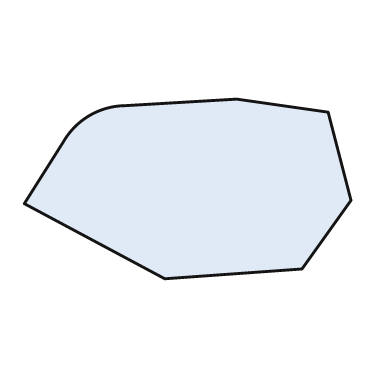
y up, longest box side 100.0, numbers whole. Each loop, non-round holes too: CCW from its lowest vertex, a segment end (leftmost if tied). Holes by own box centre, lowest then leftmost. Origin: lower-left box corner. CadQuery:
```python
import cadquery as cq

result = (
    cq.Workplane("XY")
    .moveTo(43.0, 0.0)
    .lineTo(85.0, 3.0)
    .lineTo(100.0, 24.0)
    .lineTo(93.0, 51.0)
    .lineTo(65.0, 55.0)
    .lineTo(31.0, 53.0)
    .threePointArc((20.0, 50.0), (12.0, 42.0))
    .lineTo(0.0, 23.0)
    .close()
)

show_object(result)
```